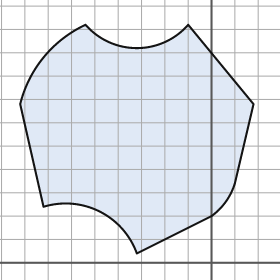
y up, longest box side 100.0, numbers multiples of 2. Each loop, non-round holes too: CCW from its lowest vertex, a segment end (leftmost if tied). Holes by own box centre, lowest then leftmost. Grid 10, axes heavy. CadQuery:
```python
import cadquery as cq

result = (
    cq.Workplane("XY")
    .moveTo(-32.0, 4.0)
    .lineTo(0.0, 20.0)
    .threePointArc((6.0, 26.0), (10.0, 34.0))
    .lineTo(18.0, 68.0)
    .lineTo(-10.0, 102.0)
    .threePointArc((-32.0, 92.0), (-54.0, 102.0))
    .threePointArc((-72.0, 88.0), (-82.0, 68.0))
    .lineTo(-72.0, 24.0)
    .threePointArc((-48.0, 22.0), (-32.0, 4.0))
    .close()
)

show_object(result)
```